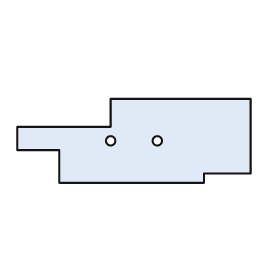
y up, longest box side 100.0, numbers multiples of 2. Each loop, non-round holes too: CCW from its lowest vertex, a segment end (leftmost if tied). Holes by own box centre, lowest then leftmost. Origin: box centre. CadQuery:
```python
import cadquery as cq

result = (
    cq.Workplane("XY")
    .moveTo(-32.0, -18.0)
    .lineTo(30.0, -18.0)
    .lineTo(30.0, -14.0)
    .lineTo(50.0, -14.0)
    .lineTo(50.0, 18.0)
    .lineTo(-10.0, 18.0)
    .lineTo(-10.0, 6.0)
    .lineTo(-50.0, 6.0)
    .lineTo(-50.0, -4.0)
    .lineTo(-32.0, -4.0)
    .close()
    .moveTo(-10.0, 0.0)
    .circle(2.0)
    .moveTo(10.0, 0.0)
    .circle(2.0)
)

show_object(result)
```